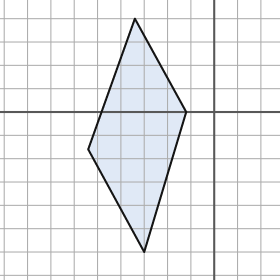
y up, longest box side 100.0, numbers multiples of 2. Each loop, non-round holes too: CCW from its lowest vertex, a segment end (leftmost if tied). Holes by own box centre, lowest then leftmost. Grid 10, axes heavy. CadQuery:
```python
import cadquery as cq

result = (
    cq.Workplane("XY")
    .moveTo(-30.0, -60.0)
    .lineTo(-12.0, 0.0)
    .lineTo(-34.0, 40.0)
    .lineTo(-54.0, -16.0)
    .close()
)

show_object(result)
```